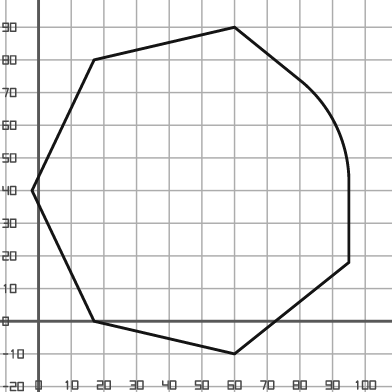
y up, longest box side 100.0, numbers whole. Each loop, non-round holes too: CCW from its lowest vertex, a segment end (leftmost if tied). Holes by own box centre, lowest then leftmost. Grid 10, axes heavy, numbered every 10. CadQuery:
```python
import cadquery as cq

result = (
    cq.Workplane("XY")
    .moveTo(60.0, -10.0)
    .lineTo(95.0, 18.0)
    .lineTo(95.0, 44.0)
    .threePointArc((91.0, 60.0), (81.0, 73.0))
    .lineTo(60.0, 90.0)
    .lineTo(17.0, 80.0)
    .lineTo(-2.0, 40.0)
    .lineTo(17.0, 0.0)
    .close()
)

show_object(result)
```